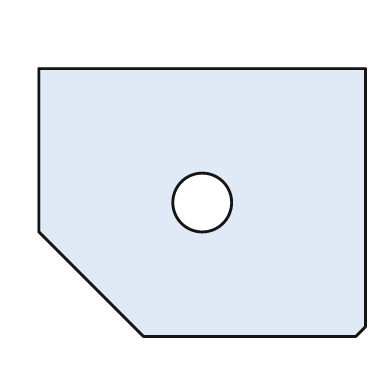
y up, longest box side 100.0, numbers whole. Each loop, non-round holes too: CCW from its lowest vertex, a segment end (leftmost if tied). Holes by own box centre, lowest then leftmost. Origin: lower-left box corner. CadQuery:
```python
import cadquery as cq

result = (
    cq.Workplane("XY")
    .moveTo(32.0, 0.0)
    .lineTo(97.0, 0.0)
    .lineTo(100.0, 3.0)
    .lineTo(100.0, 82.0)
    .lineTo(0.0, 82.0)
    .lineTo(0.0, 32.0)
    .close()
    .moveTo(50.0, 41.0)
    .circle(9.0)
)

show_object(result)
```